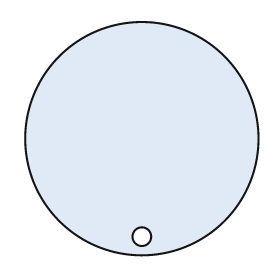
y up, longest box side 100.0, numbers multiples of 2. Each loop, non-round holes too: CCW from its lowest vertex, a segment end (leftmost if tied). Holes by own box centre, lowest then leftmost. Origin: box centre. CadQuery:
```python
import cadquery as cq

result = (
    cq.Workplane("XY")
    .moveTo(0.0, 0.0)
    .circle(50.0)
    .moveTo(0.0, -42.0)
    .circle(4.0)
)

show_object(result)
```